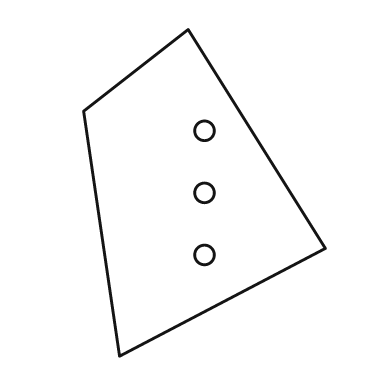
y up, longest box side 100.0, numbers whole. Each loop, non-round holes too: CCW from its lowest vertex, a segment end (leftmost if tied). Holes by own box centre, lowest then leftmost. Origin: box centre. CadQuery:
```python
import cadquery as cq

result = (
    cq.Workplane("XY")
    .moveTo(-26.0, -50.0)
    .lineTo(37.0, -17.0)
    .lineTo(-5.0, 50.0)
    .lineTo(-37.0, 25.0)
    .close()
    .moveTo(0.0, -19.0)
    .circle(3.0)
    .moveTo(0.0, 0.0)
    .circle(3.0)
    .moveTo(0.0, 19.0)
    .circle(3.0)
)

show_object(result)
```